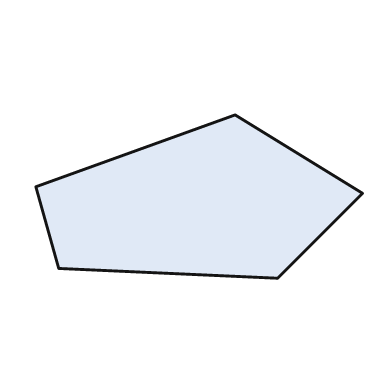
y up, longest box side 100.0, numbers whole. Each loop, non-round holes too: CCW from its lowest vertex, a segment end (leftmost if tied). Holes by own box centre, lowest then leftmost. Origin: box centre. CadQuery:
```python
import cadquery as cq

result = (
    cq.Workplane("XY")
    .moveTo(24.0, -25.0)
    .lineTo(50.0, 1.0)
    .lineTo(11.0, 25.0)
    .lineTo(-50.0, 3.0)
    .lineTo(-43.0, -22.0)
    .close()
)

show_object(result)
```